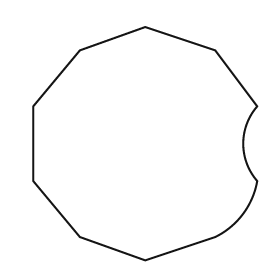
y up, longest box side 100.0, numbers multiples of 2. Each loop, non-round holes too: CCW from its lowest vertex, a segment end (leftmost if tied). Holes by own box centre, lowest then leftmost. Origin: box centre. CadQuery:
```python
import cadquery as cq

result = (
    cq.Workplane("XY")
    .moveTo(0.0, -50.0)
    .lineTo(30.0, -40.0)
    .threePointArc((42.0, -30.0), (48.0, -16.0))
    .threePointArc((42.0, 0.0), (48.0, 16.0))
    .lineTo(30.0, 40.0)
    .lineTo(0.0, 50.0)
    .lineTo(-28.0, 40.0)
    .lineTo(-48.0, 16.0)
    .lineTo(-48.0, -16.0)
    .lineTo(-28.0, -40.0)
    .close()
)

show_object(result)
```